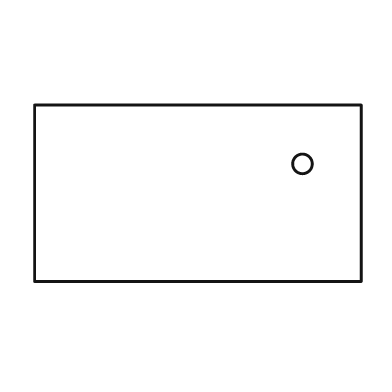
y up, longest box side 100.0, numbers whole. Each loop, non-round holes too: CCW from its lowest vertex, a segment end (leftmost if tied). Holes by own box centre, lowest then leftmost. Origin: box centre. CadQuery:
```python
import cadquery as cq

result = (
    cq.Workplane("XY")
    .moveTo(-50.0, -27.0)
    .lineTo(50.0, -27.0)
    .lineTo(50.0, 27.0)
    .lineTo(-50.0, 27.0)
    .close()
    .moveTo(32.0, 9.0)
    .circle(3.0)
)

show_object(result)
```